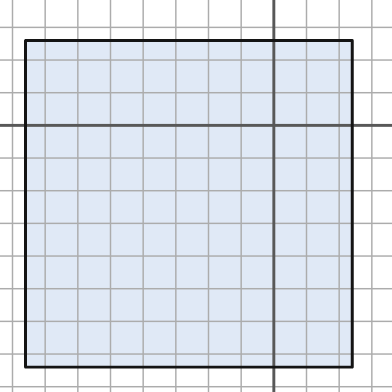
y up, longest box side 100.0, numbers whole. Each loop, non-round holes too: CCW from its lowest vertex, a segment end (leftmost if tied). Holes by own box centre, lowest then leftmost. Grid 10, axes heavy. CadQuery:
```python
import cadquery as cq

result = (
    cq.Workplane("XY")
    .moveTo(-76.0, -74.0)
    .lineTo(24.0, -74.0)
    .lineTo(24.0, 26.0)
    .lineTo(-76.0, 26.0)
    .close()
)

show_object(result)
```